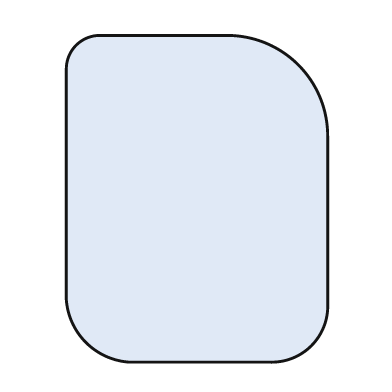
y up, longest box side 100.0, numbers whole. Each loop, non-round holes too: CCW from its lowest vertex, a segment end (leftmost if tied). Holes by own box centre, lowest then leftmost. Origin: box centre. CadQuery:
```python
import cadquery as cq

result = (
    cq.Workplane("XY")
    .moveTo(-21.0, -50.0)
    .lineTo(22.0, -50.0)
    .threePointArc((35.0, -45.0), (40.0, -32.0))
    .lineTo(40.0, 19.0)
    .threePointArc((31.0, 41.0), (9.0, 50.0))
    .lineTo(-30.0, 50.0)
    .threePointArc((-37.0, 47.0), (-40.0, 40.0))
    .lineTo(-40.0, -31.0)
    .threePointArc((-34.0, -44.0), (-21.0, -50.0))
    .close()
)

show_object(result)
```